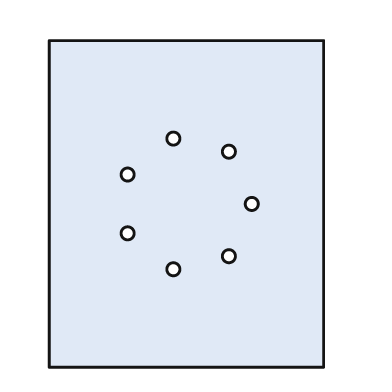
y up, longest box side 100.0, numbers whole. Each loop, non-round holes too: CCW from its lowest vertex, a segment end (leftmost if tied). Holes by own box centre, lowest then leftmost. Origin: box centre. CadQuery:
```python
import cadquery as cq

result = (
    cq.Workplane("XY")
    .moveTo(-42.0, -50.0)
    .lineTo(42.0, -50.0)
    .lineTo(42.0, 50.0)
    .lineTo(-42.0, 50.0)
    .close()
    .moveTo(-4.0, -20.0)
    .circle(2.0)
    .moveTo(13.0, -16.0)
    .circle(2.0)
    .moveTo(-18.0, -9.0)
    .circle(2.0)
    .moveTo(20.0, 0.0)
    .circle(2.0)
    .moveTo(-18.0, 9.0)
    .circle(2.0)
    .moveTo(13.0, 16.0)
    .circle(2.0)
    .moveTo(-4.0, 20.0)
    .circle(2.0)
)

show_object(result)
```